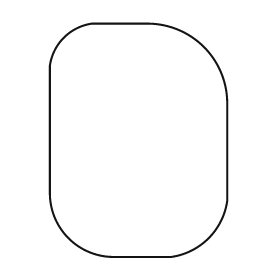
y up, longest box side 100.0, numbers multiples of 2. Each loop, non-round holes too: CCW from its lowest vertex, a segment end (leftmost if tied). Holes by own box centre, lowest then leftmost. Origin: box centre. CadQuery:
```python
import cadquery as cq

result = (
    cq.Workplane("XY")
    .moveTo(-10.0, -50.0)
    .lineTo(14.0, -50.0)
    .threePointArc((30.0, -42.0), (38.0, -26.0))
    .lineTo(38.0, 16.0)
    .threePointArc((28.0, 40.0), (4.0, 50.0))
    .lineTo(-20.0, 50.0)
    .threePointArc((-32.0, 44.0), (-38.0, 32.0))
    .lineTo(-38.0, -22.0)
    .threePointArc((-30.0, -42.0), (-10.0, -50.0))
    .close()
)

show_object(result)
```